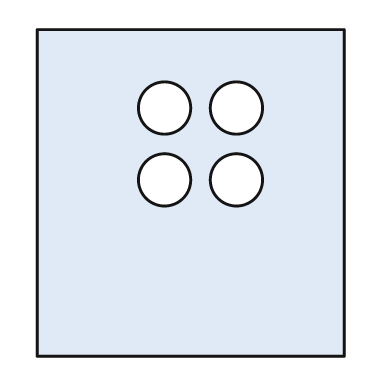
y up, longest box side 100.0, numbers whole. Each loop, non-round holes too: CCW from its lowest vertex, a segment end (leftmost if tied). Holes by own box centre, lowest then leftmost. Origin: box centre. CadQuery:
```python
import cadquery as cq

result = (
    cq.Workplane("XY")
    .moveTo(-47.0, -50.0)
    .lineTo(47.0, -50.0)
    .lineTo(47.0, 50.0)
    .lineTo(-47.0, 50.0)
    .close()
    .moveTo(-8.0, 4.0)
    .circle(8.0)
    .moveTo(14.0, 4.0)
    .circle(8.0)
    .moveTo(-8.0, 26.0)
    .circle(8.0)
    .moveTo(14.0, 26.0)
    .circle(8.0)
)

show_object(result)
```